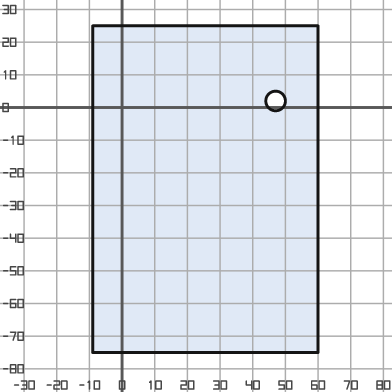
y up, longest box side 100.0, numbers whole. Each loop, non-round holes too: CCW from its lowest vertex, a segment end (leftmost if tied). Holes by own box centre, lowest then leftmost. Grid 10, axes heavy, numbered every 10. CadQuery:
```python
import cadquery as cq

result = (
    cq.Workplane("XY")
    .moveTo(-9.0, -75.0)
    .lineTo(60.0, -75.0)
    .lineTo(60.0, 25.0)
    .lineTo(-9.0, 25.0)
    .close()
    .moveTo(47.0, 2.0)
    .circle(3.0)
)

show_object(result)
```